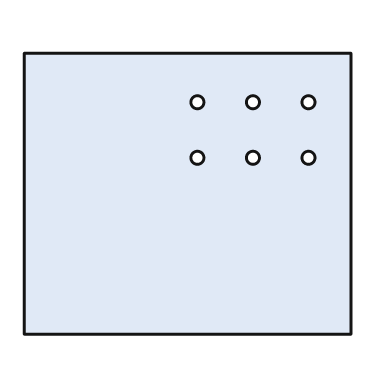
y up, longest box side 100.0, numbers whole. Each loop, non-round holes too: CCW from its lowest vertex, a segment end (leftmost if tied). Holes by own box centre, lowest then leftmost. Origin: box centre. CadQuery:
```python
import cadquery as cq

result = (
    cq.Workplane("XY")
    .moveTo(-50.0, -43.0)
    .lineTo(50.0, -43.0)
    .lineTo(50.0, 43.0)
    .lineTo(-50.0, 43.0)
    .close()
    .moveTo(3.0, 11.0)
    .circle(2.0)
    .moveTo(20.0, 11.0)
    .circle(2.0)
    .moveTo(37.0, 11.0)
    .circle(2.0)
    .moveTo(3.0, 28.0)
    .circle(2.0)
    .moveTo(20.0, 28.0)
    .circle(2.0)
    .moveTo(37.0, 28.0)
    .circle(2.0)
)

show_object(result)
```